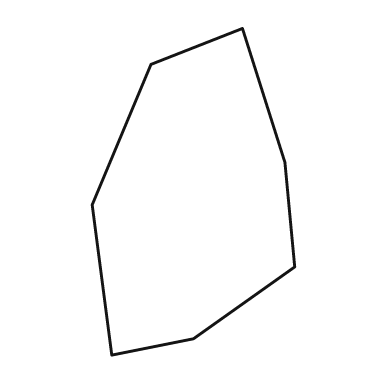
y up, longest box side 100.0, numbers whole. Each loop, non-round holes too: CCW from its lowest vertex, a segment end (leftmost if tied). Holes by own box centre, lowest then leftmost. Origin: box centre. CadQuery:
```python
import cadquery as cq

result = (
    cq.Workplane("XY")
    .moveTo(-25.0, -50.0)
    .lineTo(0.0, -45.0)
    .lineTo(31.0, -23.0)
    .lineTo(28.0, 9.0)
    .lineTo(15.0, 50.0)
    .lineTo(-13.0, 39.0)
    .lineTo(-31.0, -4.0)
    .close()
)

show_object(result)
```